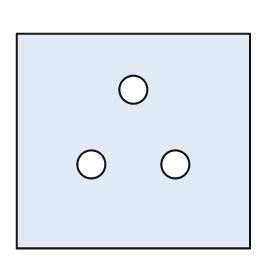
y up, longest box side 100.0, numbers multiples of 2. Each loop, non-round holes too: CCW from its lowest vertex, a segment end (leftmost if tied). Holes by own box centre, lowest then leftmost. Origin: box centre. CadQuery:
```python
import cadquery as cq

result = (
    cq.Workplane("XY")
    .moveTo(-50.0, -46.0)
    .lineTo(50.0, -46.0)
    .lineTo(50.0, 46.0)
    .lineTo(-50.0, 46.0)
    .close()
    .moveTo(-18.0, -10.0)
    .circle(6.0)
    .moveTo(18.0, -10.0)
    .circle(6.0)
    .moveTo(0.0, 22.0)
    .circle(6.0)
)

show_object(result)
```